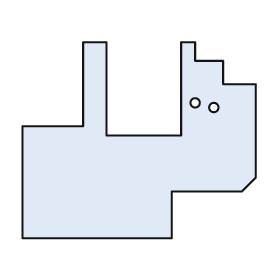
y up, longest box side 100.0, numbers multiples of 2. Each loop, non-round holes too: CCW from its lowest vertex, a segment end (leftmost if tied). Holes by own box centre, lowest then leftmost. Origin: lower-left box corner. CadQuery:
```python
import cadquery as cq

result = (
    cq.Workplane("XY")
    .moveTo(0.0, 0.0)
    .lineTo(64.0, 0.0)
    .lineTo(64.0, 20.0)
    .lineTo(94.0, 20.0)
    .lineTo(100.0, 26.0)
    .lineTo(100.0, 66.0)
    .lineTo(86.0, 66.0)
    .lineTo(86.0, 76.0)
    .lineTo(74.0, 76.0)
    .lineTo(74.0, 84.0)
    .lineTo(68.0, 84.0)
    .lineTo(68.0, 44.0)
    .lineTo(36.0, 44.0)
    .lineTo(36.0, 84.0)
    .lineTo(26.0, 84.0)
    .lineTo(26.0, 48.0)
    .lineTo(0.0, 48.0)
    .close()
    .moveTo(82.0, 56.0)
    .circle(2.0)
    .moveTo(74.0, 58.0)
    .circle(2.0)
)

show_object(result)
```